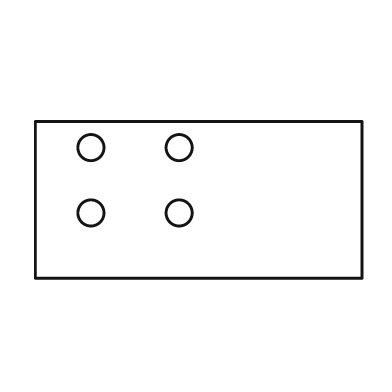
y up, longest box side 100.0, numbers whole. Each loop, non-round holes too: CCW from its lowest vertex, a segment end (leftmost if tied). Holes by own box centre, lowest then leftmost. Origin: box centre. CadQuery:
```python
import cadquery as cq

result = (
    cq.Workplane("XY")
    .moveTo(-50.0, -24.0)
    .lineTo(50.0, -24.0)
    .lineTo(50.0, 24.0)
    .lineTo(-50.0, 24.0)
    .close()
    .moveTo(-33.0, -4.0)
    .circle(4.0)
    .moveTo(-6.0, -4.0)
    .circle(4.0)
    .moveTo(-33.0, 16.0)
    .circle(4.0)
    .moveTo(-6.0, 16.0)
    .circle(4.0)
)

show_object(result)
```